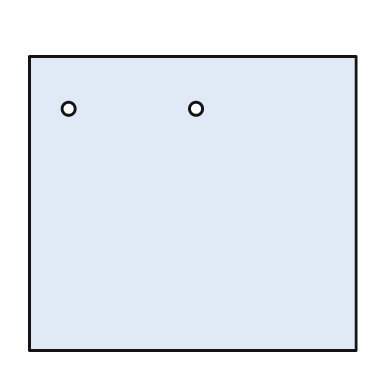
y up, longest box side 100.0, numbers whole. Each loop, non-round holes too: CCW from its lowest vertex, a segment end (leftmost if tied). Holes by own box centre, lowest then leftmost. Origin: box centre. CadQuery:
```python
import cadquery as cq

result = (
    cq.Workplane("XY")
    .moveTo(-50.0, -45.0)
    .lineTo(50.0, -45.0)
    .lineTo(50.0, 45.0)
    .lineTo(-50.0, 45.0)
    .close()
    .moveTo(-38.0, 29.0)
    .circle(2.0)
    .moveTo(1.0, 29.0)
    .circle(2.0)
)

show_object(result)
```